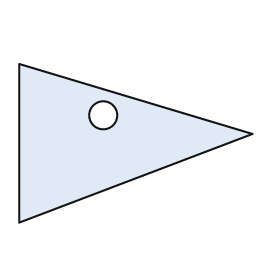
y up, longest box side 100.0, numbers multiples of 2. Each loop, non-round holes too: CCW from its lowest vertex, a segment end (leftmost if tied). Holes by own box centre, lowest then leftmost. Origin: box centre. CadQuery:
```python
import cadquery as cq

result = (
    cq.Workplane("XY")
    .moveTo(-50.0, -34.0)
    .lineTo(50.0, 4.0)
    .lineTo(-50.0, 34.0)
    .close()
    .moveTo(-14.0, 12.0)
    .circle(6.0)
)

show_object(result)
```